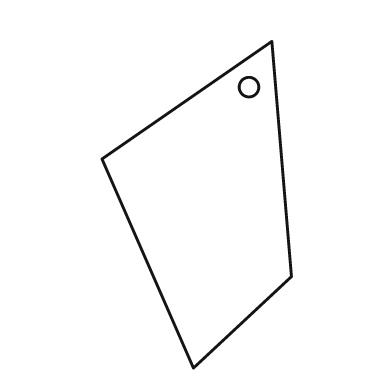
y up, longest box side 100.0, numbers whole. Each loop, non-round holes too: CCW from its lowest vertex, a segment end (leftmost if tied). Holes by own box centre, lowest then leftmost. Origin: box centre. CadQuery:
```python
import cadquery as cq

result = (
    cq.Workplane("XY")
    .moveTo(-1.0, -50.0)
    .lineTo(29.0, -22.0)
    .lineTo(23.0, 50.0)
    .lineTo(-29.0, 14.0)
    .close()
    .moveTo(16.0, 36.0)
    .circle(3.0)
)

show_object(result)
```